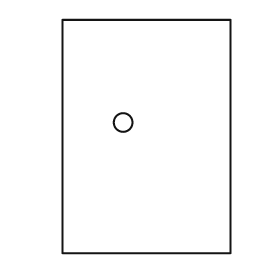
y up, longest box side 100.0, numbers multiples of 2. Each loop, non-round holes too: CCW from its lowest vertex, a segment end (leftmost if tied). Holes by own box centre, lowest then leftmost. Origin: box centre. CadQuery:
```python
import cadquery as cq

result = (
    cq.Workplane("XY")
    .moveTo(-36.0, -50.0)
    .lineTo(36.0, -50.0)
    .lineTo(36.0, 50.0)
    .lineTo(-36.0, 50.0)
    .close()
    .moveTo(-10.0, 6.0)
    .circle(4.0)
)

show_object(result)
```